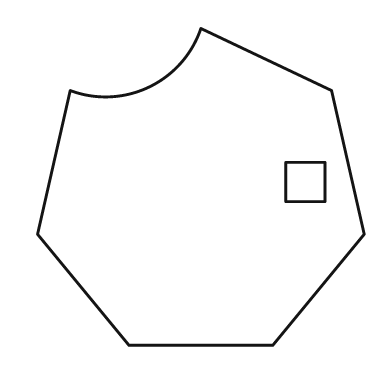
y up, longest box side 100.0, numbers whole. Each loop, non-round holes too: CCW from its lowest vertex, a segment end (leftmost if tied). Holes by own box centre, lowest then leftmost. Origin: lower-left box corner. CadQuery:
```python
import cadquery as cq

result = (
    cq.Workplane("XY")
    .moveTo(28.0, 0.0)
    .lineTo(72.0, 0.0)
    .lineTo(100.0, 34.0)
    .lineTo(90.0, 78.0)
    .lineTo(50.0, 97.0)
    .threePointArc((34.0, 79.0), (10.0, 78.0))
    .lineTo(0.0, 34.0)
    .close()
    .moveTo(76.0, 44.0)
    .lineTo(88.0, 44.0)
    .lineTo(88.0, 56.0)
    .lineTo(76.0, 56.0)
    .close()
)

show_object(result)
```